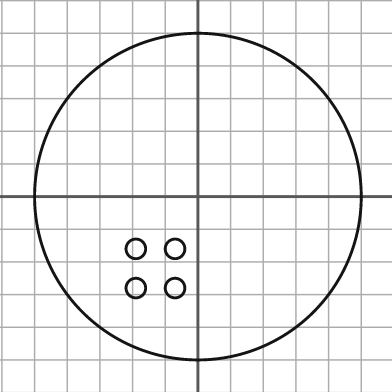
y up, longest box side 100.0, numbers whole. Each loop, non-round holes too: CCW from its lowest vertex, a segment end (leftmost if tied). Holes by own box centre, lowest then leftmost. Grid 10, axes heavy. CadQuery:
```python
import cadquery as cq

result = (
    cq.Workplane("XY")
    .moveTo(0.0, 0.0)
    .circle(50.0)
    .moveTo(-19.0, -28.0)
    .circle(3.0)
    .moveTo(-7.0, -28.0)
    .circle(3.0)
    .moveTo(-19.0, -16.0)
    .circle(3.0)
    .moveTo(-7.0, -16.0)
    .circle(3.0)
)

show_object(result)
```